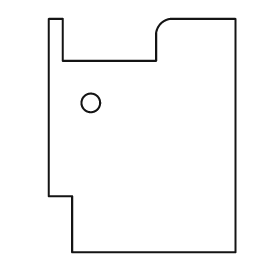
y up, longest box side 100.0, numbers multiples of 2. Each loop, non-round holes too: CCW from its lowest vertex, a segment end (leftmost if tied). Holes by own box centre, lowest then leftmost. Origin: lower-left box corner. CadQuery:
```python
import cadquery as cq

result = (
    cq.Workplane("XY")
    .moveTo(10.0, 0.0)
    .lineTo(80.0, 0.0)
    .lineTo(80.0, 100.0)
    .lineTo(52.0, 100.0)
    .threePointArc((48.0, 98.0), (46.0, 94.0))
    .lineTo(46.0, 82.0)
    .lineTo(6.0, 82.0)
    .lineTo(6.0, 100.0)
    .lineTo(0.0, 100.0)
    .lineTo(0.0, 24.0)
    .lineTo(10.0, 24.0)
    .close()
    .moveTo(18.0, 64.0)
    .circle(4.0)
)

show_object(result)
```